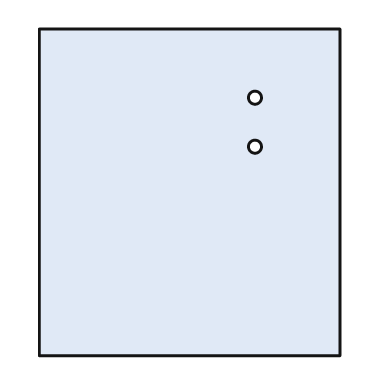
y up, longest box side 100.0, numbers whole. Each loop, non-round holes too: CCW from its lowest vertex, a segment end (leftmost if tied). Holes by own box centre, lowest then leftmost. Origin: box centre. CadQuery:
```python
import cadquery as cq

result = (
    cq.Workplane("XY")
    .moveTo(-46.0, -50.0)
    .lineTo(46.0, -50.0)
    .lineTo(46.0, 50.0)
    .lineTo(-46.0, 50.0)
    .close()
    .moveTo(20.0, 14.0)
    .circle(2.0)
    .moveTo(20.0, 29.0)
    .circle(2.0)
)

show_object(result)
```